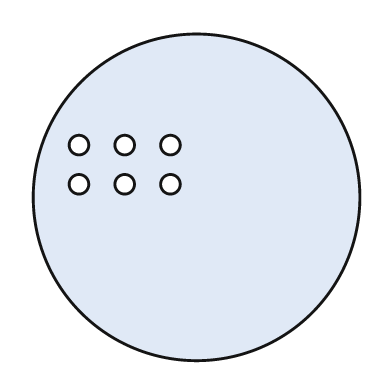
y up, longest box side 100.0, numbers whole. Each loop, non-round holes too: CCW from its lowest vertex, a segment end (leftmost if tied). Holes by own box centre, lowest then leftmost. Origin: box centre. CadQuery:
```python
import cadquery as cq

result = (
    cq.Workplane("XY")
    .moveTo(0.0, 0.0)
    .circle(50.0)
    .moveTo(-36.0, 4.0)
    .circle(3.0)
    .moveTo(-22.0, 4.0)
    .circle(3.0)
    .moveTo(-8.0, 4.0)
    .circle(3.0)
    .moveTo(-36.0, 16.0)
    .circle(3.0)
    .moveTo(-22.0, 16.0)
    .circle(3.0)
    .moveTo(-8.0, 16.0)
    .circle(3.0)
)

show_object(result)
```